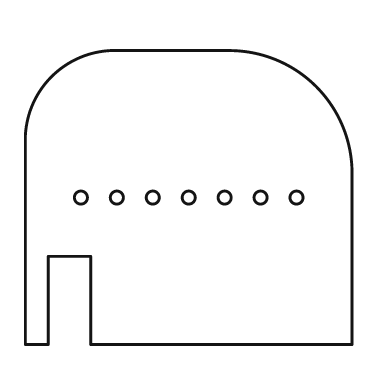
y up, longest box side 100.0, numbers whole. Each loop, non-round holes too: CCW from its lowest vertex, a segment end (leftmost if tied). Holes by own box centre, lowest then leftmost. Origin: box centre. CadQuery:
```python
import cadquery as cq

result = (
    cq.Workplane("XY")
    .moveTo(-50.0, -45.0)
    .lineTo(-43.0, -45.0)
    .lineTo(-43.0, -18.0)
    .lineTo(-30.0, -18.0)
    .lineTo(-30.0, -45.0)
    .lineTo(50.0, -45.0)
    .lineTo(50.0, 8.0)
    .threePointArc((39.0, 34.0), (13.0, 45.0))
    .lineTo(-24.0, 45.0)
    .threePointArc((-42.0, 37.0), (-50.0, 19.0))
    .close()
    .moveTo(-33.0, 0.0)
    .circle(2.0)
    .moveTo(-22.0, 0.0)
    .circle(2.0)
    .moveTo(-11.0, 0.0)
    .circle(2.0)
    .moveTo(0.0, 0.0)
    .circle(2.0)
    .moveTo(11.0, 0.0)
    .circle(2.0)
    .moveTo(22.0, 0.0)
    .circle(2.0)
    .moveTo(33.0, 0.0)
    .circle(2.0)
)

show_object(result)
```